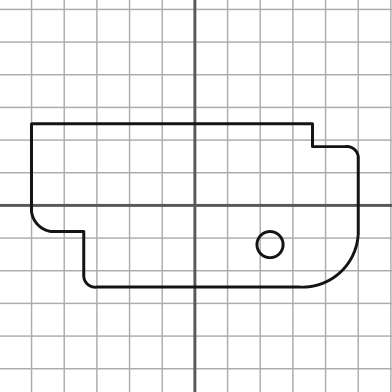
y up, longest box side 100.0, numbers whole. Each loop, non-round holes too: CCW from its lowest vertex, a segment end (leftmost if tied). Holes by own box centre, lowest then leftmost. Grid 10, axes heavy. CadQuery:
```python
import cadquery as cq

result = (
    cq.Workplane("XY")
    .moveTo(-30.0, -25.0)
    .lineTo(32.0, -25.0)
    .threePointArc((45.0, -20.0), (50.0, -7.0))
    .lineTo(50.0, 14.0)
    .threePointArc((49.0, 17.0), (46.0, 18.0))
    .lineTo(36.0, 18.0)
    .lineTo(36.0, 25.0)
    .lineTo(-50.0, 25.0)
    .lineTo(-50.0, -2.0)
    .threePointArc((-48.0, -6.0), (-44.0, -8.0))
    .lineTo(-34.0, -8.0)
    .lineTo(-34.0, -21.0)
    .threePointArc((-33.0, -24.0), (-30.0, -25.0))
    .close()
    .moveTo(23.0, -12.0)
    .circle(4.0)
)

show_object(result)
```